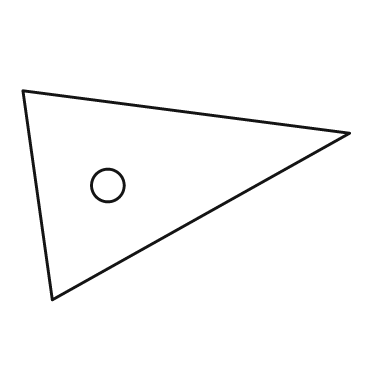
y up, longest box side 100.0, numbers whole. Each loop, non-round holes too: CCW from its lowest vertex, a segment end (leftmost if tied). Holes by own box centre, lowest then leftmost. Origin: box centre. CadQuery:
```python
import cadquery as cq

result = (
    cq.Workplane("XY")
    .moveTo(-41.0, -32.0)
    .lineTo(50.0, 19.0)
    .lineTo(-50.0, 32.0)
    .close()
    .moveTo(-24.0, 3.0)
    .circle(5.0)
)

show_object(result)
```